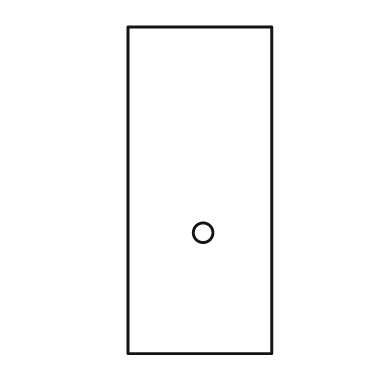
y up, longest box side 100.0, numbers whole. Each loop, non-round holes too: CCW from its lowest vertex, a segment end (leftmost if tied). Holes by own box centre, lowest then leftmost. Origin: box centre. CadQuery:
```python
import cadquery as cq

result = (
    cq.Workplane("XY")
    .moveTo(-22.0, -50.0)
    .lineTo(22.0, -50.0)
    .lineTo(22.0, 50.0)
    .lineTo(-22.0, 50.0)
    .close()
    .moveTo(1.0, -13.0)
    .circle(3.0)
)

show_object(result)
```